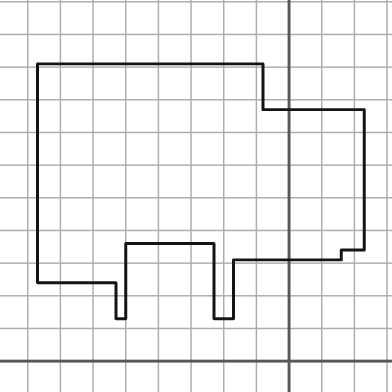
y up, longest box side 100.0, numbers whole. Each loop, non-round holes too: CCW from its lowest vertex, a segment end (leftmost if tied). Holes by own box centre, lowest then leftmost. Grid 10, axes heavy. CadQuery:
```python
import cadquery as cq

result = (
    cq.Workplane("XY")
    .moveTo(-53.0, 13.0)
    .lineTo(-50.0, 13.0)
    .lineTo(-50.0, 36.0)
    .lineTo(-23.0, 36.0)
    .lineTo(-23.0, 13.0)
    .lineTo(-17.0, 13.0)
    .lineTo(-17.0, 31.0)
    .lineTo(16.0, 31.0)
    .lineTo(16.0, 34.0)
    .lineTo(23.0, 34.0)
    .lineTo(23.0, 77.0)
    .lineTo(-8.0, 77.0)
    .lineTo(-8.0, 91.0)
    .lineTo(-77.0, 91.0)
    .lineTo(-77.0, 24.0)
    .lineTo(-53.0, 24.0)
    .close()
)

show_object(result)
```